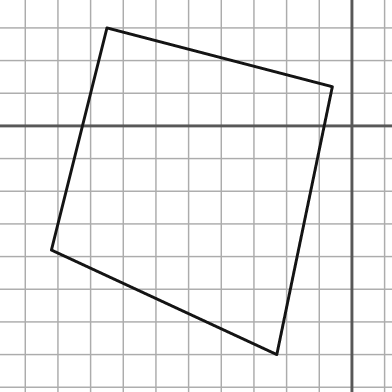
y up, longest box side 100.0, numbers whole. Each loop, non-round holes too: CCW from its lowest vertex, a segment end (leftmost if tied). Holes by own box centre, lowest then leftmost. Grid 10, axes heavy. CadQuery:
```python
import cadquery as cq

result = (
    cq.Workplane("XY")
    .moveTo(-23.0, -70.0)
    .lineTo(-6.0, 12.0)
    .lineTo(-75.0, 30.0)
    .lineTo(-92.0, -38.0)
    .close()
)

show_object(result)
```